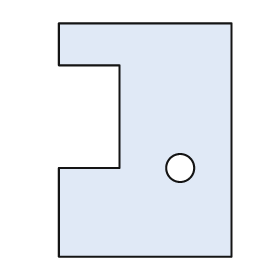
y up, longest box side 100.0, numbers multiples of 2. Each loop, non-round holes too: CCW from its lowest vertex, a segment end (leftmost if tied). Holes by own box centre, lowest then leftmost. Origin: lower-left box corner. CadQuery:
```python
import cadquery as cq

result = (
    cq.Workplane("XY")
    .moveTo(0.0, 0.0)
    .lineTo(74.0, 0.0)
    .lineTo(74.0, 100.0)
    .lineTo(0.0, 100.0)
    .lineTo(0.0, 82.0)
    .lineTo(26.0, 82.0)
    .lineTo(26.0, 38.0)
    .lineTo(0.0, 38.0)
    .close()
    .moveTo(52.0, 38.0)
    .circle(6.0)
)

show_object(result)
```